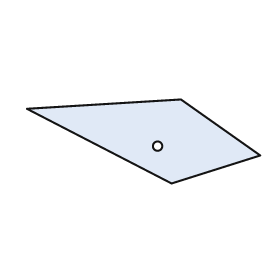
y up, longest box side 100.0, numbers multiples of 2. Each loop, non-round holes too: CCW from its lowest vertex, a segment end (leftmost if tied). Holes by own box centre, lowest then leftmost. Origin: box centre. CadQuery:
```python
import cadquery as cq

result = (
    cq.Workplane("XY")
    .moveTo(12.0, -18.0)
    .lineTo(50.0, -6.0)
    .lineTo(16.0, 18.0)
    .lineTo(-50.0, 14.0)
    .close()
    .moveTo(6.0, -2.0)
    .circle(2.0)
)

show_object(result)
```